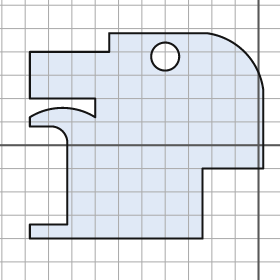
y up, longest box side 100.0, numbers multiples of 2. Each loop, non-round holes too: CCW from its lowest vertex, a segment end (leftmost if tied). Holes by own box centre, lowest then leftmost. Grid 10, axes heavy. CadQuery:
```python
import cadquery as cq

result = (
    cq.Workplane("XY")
    .moveTo(-98.0, -40.0)
    .lineTo(-24.0, -40.0)
    .lineTo(-24.0, -10.0)
    .lineTo(2.0, -10.0)
    .lineTo(2.0, 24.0)
    .threePointArc((-6.0, 40.0), (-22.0, 48.0))
    .lineTo(-64.0, 48.0)
    .lineTo(-64.0, 40.0)
    .lineTo(-98.0, 40.0)
    .lineTo(-98.0, 20.0)
    .lineTo(-70.0, 20.0)
    .lineTo(-70.0, 12.0)
    .threePointArc((-84.0, 16.0), (-98.0, 12.0))
    .lineTo(-98.0, 8.0)
    .lineTo(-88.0, 8.0)
    .threePointArc((-84.0, 6.0), (-82.0, 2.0))
    .lineTo(-82.0, -34.0)
    .lineTo(-98.0, -34.0)
    .close()
    .moveTo(-40.0, 38.0)
    .circle(6.0)
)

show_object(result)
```